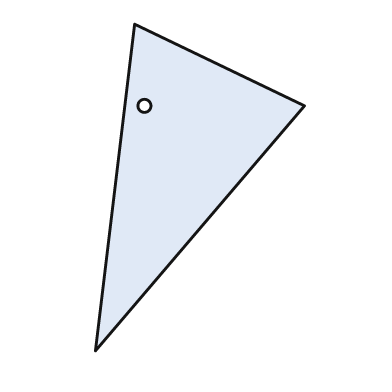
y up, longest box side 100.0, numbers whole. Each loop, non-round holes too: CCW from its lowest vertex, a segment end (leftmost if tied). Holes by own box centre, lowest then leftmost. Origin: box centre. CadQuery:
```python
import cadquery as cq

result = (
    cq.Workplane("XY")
    .moveTo(-32.0, -50.0)
    .lineTo(32.0, 25.0)
    .lineTo(-20.0, 50.0)
    .close()
    .moveTo(-17.0, 25.0)
    .circle(2.0)
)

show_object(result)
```